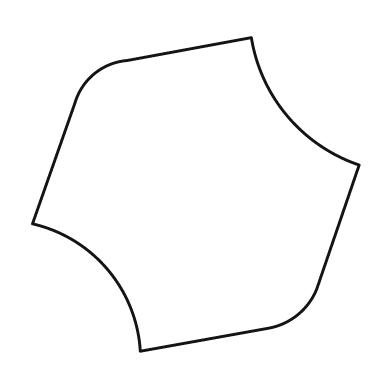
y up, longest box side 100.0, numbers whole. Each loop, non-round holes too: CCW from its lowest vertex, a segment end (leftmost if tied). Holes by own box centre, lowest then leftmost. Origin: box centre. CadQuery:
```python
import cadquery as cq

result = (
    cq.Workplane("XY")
    .moveTo(-17.0, -48.0)
    .lineTo(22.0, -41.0)
    .threePointArc((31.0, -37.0), (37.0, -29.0))
    .lineTo(50.0, 9.0)
    .threePointArc((28.0, 24.0), (17.0, 48.0))
    .lineTo(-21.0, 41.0)
    .threePointArc((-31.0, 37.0), (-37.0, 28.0))
    .lineTo(-50.0, -9.0)
    .threePointArc((-27.0, -23.0), (-17.0, -48.0))
    .close()
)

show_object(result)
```